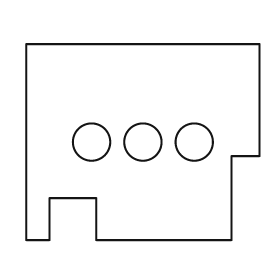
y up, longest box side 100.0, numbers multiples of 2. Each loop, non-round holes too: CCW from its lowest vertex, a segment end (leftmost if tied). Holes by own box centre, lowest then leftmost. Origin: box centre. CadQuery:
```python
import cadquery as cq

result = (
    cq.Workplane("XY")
    .moveTo(-50.0, -42.0)
    .lineTo(-40.0, -42.0)
    .lineTo(-40.0, -24.0)
    .lineTo(-20.0, -24.0)
    .lineTo(-20.0, -42.0)
    .lineTo(38.0, -42.0)
    .lineTo(38.0, -6.0)
    .lineTo(50.0, -6.0)
    .lineTo(50.0, 42.0)
    .lineTo(-50.0, 42.0)
    .close()
    .moveTo(-22.0, 0.0)
    .circle(8.0)
    .moveTo(0.0, 0.0)
    .circle(8.0)
    .moveTo(22.0, 0.0)
    .circle(8.0)
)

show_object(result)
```